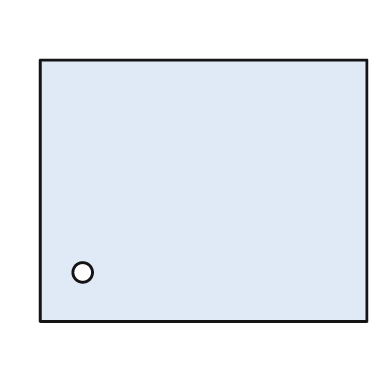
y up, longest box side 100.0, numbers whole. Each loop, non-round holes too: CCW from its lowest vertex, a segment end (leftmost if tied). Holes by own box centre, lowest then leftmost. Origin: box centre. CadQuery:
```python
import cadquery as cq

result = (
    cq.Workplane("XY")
    .moveTo(-50.0, -40.0)
    .lineTo(50.0, -40.0)
    .lineTo(50.0, 40.0)
    .lineTo(-50.0, 40.0)
    .close()
    .moveTo(-37.0, -25.0)
    .circle(3.0)
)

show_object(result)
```